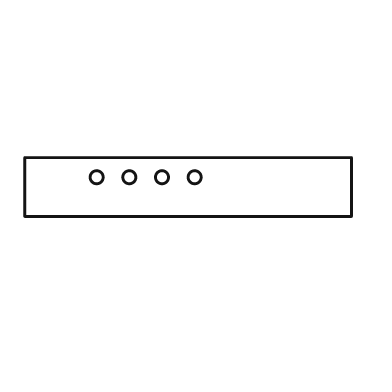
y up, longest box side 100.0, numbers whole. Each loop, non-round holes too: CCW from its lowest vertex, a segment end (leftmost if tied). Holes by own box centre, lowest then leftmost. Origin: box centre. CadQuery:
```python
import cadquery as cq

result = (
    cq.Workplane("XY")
    .moveTo(-50.0, -9.0)
    .lineTo(50.0, -9.0)
    .lineTo(50.0, 9.0)
    .lineTo(-50.0, 9.0)
    .close()
    .moveTo(-28.0, 3.0)
    .circle(2.0)
    .moveTo(-18.0, 3.0)
    .circle(2.0)
    .moveTo(-8.0, 3.0)
    .circle(2.0)
    .moveTo(2.0, 3.0)
    .circle(2.0)
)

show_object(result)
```